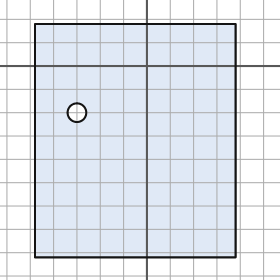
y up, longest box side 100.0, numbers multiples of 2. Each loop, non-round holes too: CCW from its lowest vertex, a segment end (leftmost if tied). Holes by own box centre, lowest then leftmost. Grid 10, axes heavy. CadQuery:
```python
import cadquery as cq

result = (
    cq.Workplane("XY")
    .moveTo(-48.0, -82.0)
    .lineTo(38.0, -82.0)
    .lineTo(38.0, 18.0)
    .lineTo(-48.0, 18.0)
    .close()
    .moveTo(-30.0, -20.0)
    .circle(4.0)
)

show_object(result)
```